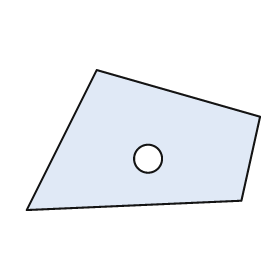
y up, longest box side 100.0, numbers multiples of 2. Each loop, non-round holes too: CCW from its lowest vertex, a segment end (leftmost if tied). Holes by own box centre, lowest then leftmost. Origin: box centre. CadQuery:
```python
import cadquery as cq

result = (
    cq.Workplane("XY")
    .moveTo(-50.0, -30.0)
    .lineTo(42.0, -26.0)
    .lineTo(50.0, 10.0)
    .lineTo(-20.0, 30.0)
    .close()
    .moveTo(2.0, -8.0)
    .circle(6.0)
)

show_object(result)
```